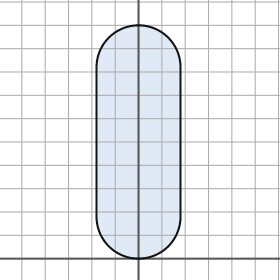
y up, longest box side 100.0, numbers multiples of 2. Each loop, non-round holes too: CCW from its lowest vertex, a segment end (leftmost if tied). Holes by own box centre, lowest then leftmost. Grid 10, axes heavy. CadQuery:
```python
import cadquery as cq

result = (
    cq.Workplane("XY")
    .moveTo(-18.0, 18.0)
    .threePointArc((0.0, 0.0), (18.0, 18.0))
    .lineTo(18.0, 82.0)
    .threePointArc((0.0, 100.0), (-18.0, 82.0))
    .close()
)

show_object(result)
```